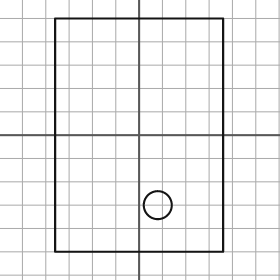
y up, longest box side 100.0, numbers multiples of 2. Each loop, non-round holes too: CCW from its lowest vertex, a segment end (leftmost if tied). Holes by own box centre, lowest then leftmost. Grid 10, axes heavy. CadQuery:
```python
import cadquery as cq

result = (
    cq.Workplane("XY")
    .moveTo(-36.0, -50.0)
    .lineTo(36.0, -50.0)
    .lineTo(36.0, 50.0)
    .lineTo(-36.0, 50.0)
    .close()
    .moveTo(8.0, -30.0)
    .circle(6.0)
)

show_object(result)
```